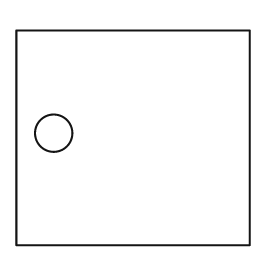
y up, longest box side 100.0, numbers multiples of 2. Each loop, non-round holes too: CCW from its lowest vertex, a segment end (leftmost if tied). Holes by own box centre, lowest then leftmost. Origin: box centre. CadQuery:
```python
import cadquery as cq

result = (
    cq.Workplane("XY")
    .moveTo(-50.0, -46.0)
    .lineTo(50.0, -46.0)
    .lineTo(50.0, 46.0)
    .lineTo(-50.0, 46.0)
    .close()
    .moveTo(-34.0, 2.0)
    .circle(8.0)
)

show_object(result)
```